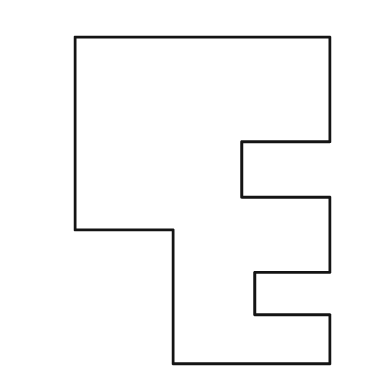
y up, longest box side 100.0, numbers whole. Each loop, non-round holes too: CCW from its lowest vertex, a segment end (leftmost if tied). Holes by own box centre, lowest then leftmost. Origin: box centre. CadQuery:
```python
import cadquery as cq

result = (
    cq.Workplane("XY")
    .moveTo(-9.0, -50.0)
    .lineTo(39.0, -50.0)
    .lineTo(39.0, -35.0)
    .lineTo(16.0, -35.0)
    .lineTo(16.0, -22.0)
    .lineTo(39.0, -22.0)
    .lineTo(39.0, 1.0)
    .lineTo(12.0, 1.0)
    .lineTo(12.0, 18.0)
    .lineTo(39.0, 18.0)
    .lineTo(39.0, 50.0)
    .lineTo(-39.0, 50.0)
    .lineTo(-39.0, -9.0)
    .lineTo(-9.0, -9.0)
    .close()
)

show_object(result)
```